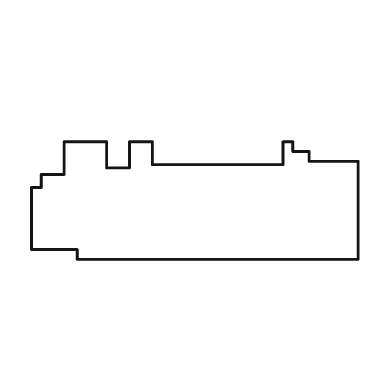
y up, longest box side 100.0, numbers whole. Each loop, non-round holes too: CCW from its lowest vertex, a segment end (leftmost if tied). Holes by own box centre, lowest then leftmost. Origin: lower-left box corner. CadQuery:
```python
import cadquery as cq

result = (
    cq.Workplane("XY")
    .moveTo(14.0, 0.0)
    .lineTo(100.0, 0.0)
    .lineTo(100.0, 30.0)
    .lineTo(85.0, 30.0)
    .lineTo(85.0, 33.0)
    .lineTo(80.0, 33.0)
    .lineTo(80.0, 36.0)
    .lineTo(77.0, 36.0)
    .lineTo(77.0, 29.0)
    .lineTo(37.0, 29.0)
    .lineTo(37.0, 36.0)
    .lineTo(30.0, 36.0)
    .lineTo(30.0, 28.0)
    .lineTo(23.0, 28.0)
    .lineTo(23.0, 36.0)
    .lineTo(10.0, 36.0)
    .lineTo(10.0, 26.0)
    .lineTo(3.0, 26.0)
    .lineTo(3.0, 22.0)
    .lineTo(0.0, 22.0)
    .lineTo(0.0, 3.0)
    .lineTo(14.0, 3.0)
    .close()
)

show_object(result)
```